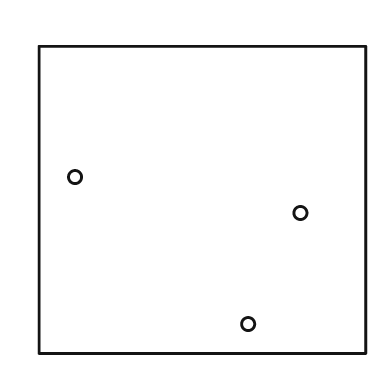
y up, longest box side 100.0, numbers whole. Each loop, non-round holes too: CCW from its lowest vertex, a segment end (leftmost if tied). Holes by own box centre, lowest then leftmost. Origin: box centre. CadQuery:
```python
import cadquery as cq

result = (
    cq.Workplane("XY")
    .moveTo(-50.0, -47.0)
    .lineTo(50.0, -47.0)
    .lineTo(50.0, 47.0)
    .lineTo(-50.0, 47.0)
    .close()
    .moveTo(14.0, -38.0)
    .circle(2.0)
    .moveTo(30.0, -4.0)
    .circle(2.0)
    .moveTo(-39.0, 7.0)
    .circle(2.0)
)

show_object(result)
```